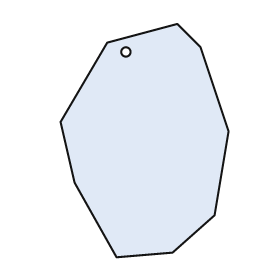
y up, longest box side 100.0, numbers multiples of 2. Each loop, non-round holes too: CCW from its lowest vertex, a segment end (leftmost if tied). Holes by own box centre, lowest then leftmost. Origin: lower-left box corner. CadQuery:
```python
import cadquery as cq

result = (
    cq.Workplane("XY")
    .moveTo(24.0, 0.0)
    .lineTo(48.0, 2.0)
    .lineTo(66.0, 18.0)
    .lineTo(72.0, 54.0)
    .lineTo(60.0, 90.0)
    .lineTo(50.0, 100.0)
    .lineTo(20.0, 92.0)
    .lineTo(0.0, 58.0)
    .lineTo(6.0, 32.0)
    .close()
    .moveTo(28.0, 88.0)
    .circle(2.0)
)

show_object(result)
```